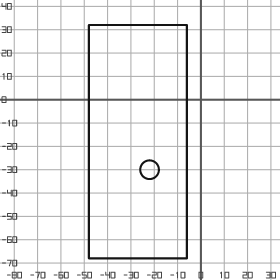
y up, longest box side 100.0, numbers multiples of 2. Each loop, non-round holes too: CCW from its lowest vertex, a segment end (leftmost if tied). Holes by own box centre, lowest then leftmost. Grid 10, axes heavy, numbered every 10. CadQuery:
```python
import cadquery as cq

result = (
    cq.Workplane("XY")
    .moveTo(-48.0, -68.0)
    .lineTo(-6.0, -68.0)
    .lineTo(-6.0, 32.0)
    .lineTo(-48.0, 32.0)
    .close()
    .moveTo(-22.0, -30.0)
    .circle(4.0)
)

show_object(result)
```